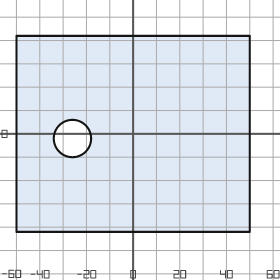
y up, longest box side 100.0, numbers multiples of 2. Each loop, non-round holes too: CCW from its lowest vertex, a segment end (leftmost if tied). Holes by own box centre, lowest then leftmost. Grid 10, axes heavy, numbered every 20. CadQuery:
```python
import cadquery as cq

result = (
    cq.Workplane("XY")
    .moveTo(-50.0, -42.0)
    .lineTo(50.0, -42.0)
    .lineTo(50.0, 42.0)
    .lineTo(-50.0, 42.0)
    .close()
    .moveTo(-26.0, -2.0)
    .circle(8.0)
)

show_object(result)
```